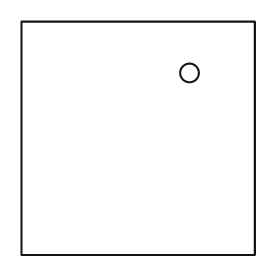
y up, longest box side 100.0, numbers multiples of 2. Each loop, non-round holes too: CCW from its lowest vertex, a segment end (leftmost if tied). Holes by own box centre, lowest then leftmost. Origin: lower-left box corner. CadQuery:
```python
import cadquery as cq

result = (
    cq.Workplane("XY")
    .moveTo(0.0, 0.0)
    .lineTo(100.0, 0.0)
    .lineTo(100.0, 100.0)
    .lineTo(0.0, 100.0)
    .close()
    .moveTo(72.0, 78.0)
    .circle(4.0)
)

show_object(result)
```